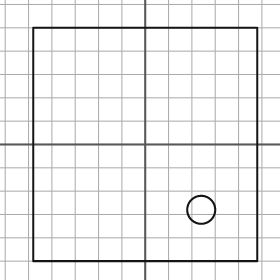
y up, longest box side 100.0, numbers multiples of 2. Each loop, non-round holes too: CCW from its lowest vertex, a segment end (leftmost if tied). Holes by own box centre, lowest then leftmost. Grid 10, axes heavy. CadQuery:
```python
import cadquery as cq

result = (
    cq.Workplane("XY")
    .moveTo(-48.0, -50.0)
    .lineTo(48.0, -50.0)
    .lineTo(48.0, 50.0)
    .lineTo(-48.0, 50.0)
    .close()
    .moveTo(24.0, -28.0)
    .circle(6.0)
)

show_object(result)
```